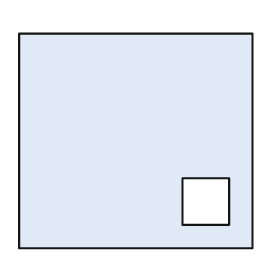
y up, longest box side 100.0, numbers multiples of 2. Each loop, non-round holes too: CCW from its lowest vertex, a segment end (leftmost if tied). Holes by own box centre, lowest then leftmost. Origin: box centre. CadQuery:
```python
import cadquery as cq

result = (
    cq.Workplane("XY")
    .moveTo(-50.0, -46.0)
    .lineTo(50.0, -46.0)
    .lineTo(50.0, 46.0)
    .lineTo(-50.0, 46.0)
    .close()
    .moveTo(20.0, -36.0)
    .lineTo(40.0, -36.0)
    .lineTo(40.0, -16.0)
    .lineTo(20.0, -16.0)
    .close()
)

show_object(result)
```